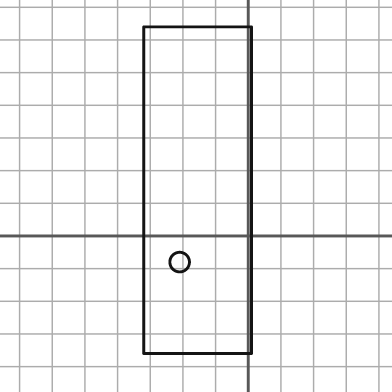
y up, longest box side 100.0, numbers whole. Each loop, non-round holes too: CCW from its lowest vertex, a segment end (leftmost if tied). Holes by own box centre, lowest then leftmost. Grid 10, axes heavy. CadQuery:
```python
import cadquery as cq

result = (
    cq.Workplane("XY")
    .moveTo(-32.0, -36.0)
    .lineTo(1.0, -36.0)
    .lineTo(1.0, 64.0)
    .lineTo(-32.0, 64.0)
    .close()
    .moveTo(-21.0, -8.0)
    .circle(3.0)
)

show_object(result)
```